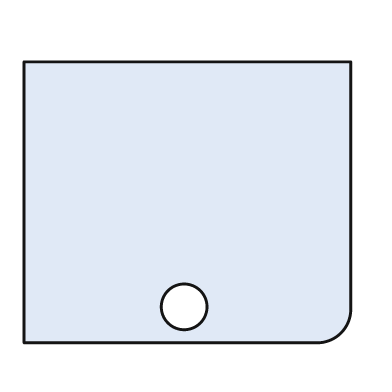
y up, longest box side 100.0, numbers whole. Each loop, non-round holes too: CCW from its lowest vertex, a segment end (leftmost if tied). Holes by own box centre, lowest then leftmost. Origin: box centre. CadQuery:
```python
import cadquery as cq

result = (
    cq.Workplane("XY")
    .moveTo(-50.0, -43.0)
    .lineTo(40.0, -43.0)
    .threePointArc((47.0, -40.0), (50.0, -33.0))
    .lineTo(50.0, 43.0)
    .lineTo(-50.0, 43.0)
    .close()
    .moveTo(-1.0, -32.0)
    .circle(7.0)
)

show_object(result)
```